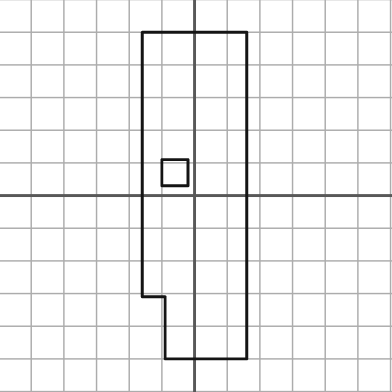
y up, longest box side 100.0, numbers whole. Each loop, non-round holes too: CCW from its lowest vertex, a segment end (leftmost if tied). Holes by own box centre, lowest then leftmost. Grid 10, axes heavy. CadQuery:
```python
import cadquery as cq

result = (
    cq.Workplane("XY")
    .moveTo(-9.0, -50.0)
    .lineTo(16.0, -50.0)
    .lineTo(16.0, 50.0)
    .lineTo(-16.0, 50.0)
    .lineTo(-16.0, -31.0)
    .lineTo(-9.0, -31.0)
    .close()
    .moveTo(-10.0, 3.0)
    .lineTo(-2.0, 3.0)
    .lineTo(-2.0, 11.0)
    .lineTo(-10.0, 11.0)
    .close()
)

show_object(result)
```